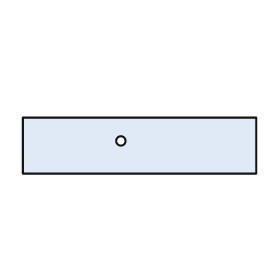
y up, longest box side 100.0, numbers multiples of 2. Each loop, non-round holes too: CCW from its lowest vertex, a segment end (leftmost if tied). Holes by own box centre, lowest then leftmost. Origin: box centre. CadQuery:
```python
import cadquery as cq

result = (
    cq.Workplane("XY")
    .moveTo(-50.0, -12.0)
    .lineTo(50.0, -12.0)
    .lineTo(50.0, 12.0)
    .lineTo(-50.0, 12.0)
    .close()
    .moveTo(-8.0, 2.0)
    .circle(2.0)
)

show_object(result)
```